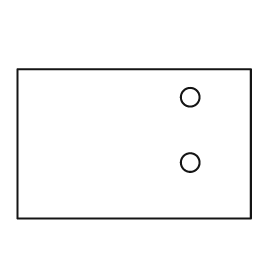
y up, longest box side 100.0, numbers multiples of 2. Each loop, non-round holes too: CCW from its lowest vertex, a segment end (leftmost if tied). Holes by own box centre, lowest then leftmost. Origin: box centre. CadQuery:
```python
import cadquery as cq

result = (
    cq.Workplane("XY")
    .moveTo(-50.0, -32.0)
    .lineTo(50.0, -32.0)
    .lineTo(50.0, 32.0)
    .lineTo(-50.0, 32.0)
    .close()
    .moveTo(24.0, -8.0)
    .circle(4.0)
    .moveTo(24.0, 20.0)
    .circle(4.0)
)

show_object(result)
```